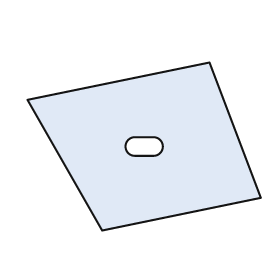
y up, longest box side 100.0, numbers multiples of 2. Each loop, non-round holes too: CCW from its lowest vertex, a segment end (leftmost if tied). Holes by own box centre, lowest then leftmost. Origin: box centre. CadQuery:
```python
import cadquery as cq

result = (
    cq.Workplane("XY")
    .moveTo(-18.0, -36.0)
    .lineTo(50.0, -22.0)
    .lineTo(28.0, 36.0)
    .lineTo(-50.0, 20.0)
    .close()
    .moveTo(-4.0, -4.0)
    .lineTo(4.0, -4.0)
    .threePointArc((8.0, 0.0), (4.0, 4.0))
    .lineTo(-4.0, 4.0)
    .threePointArc((-8.0, 0.0), (-4.0, -4.0))
    .close()
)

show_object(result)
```